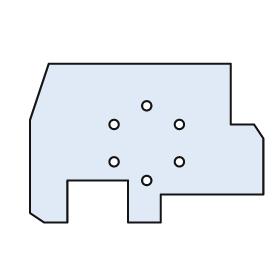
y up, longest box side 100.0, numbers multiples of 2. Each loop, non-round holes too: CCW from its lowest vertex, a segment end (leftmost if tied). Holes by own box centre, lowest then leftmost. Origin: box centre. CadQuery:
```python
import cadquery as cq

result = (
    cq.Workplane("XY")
    .moveTo(-44.0, -34.0)
    .lineTo(-34.0, -34.0)
    .lineTo(-34.0, -16.0)
    .lineTo(-8.0, -16.0)
    .lineTo(-8.0, -34.0)
    .lineTo(6.0, -34.0)
    .lineTo(6.0, -22.0)
    .lineTo(50.0, -22.0)
    .lineTo(50.0, 2.0)
    .lineTo(46.0, 8.0)
    .lineTo(36.0, 8.0)
    .lineTo(36.0, 34.0)
    .lineTo(-42.0, 34.0)
    .lineTo(-50.0, 10.0)
    .lineTo(-50.0, -30.0)
    .close()
    .moveTo(0.0, -16.0)
    .circle(2.0)
    .moveTo(-14.0, -8.0)
    .circle(2.0)
    .moveTo(14.0, -8.0)
    .circle(2.0)
    .moveTo(-14.0, 8.0)
    .circle(2.0)
    .moveTo(14.0, 8.0)
    .circle(2.0)
    .moveTo(0.0, 16.0)
    .circle(2.0)
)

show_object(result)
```